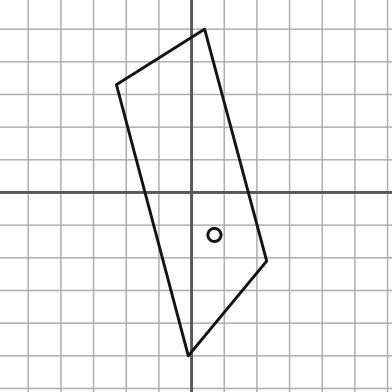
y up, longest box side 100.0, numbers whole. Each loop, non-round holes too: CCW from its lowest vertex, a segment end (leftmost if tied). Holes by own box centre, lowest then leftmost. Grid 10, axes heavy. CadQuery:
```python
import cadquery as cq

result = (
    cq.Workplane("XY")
    .moveTo(-1.0, -50.0)
    .lineTo(23.0, -21.0)
    .lineTo(4.0, 50.0)
    .lineTo(-23.0, 33.0)
    .close()
    .moveTo(7.0, -13.0)
    .circle(2.0)
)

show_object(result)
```